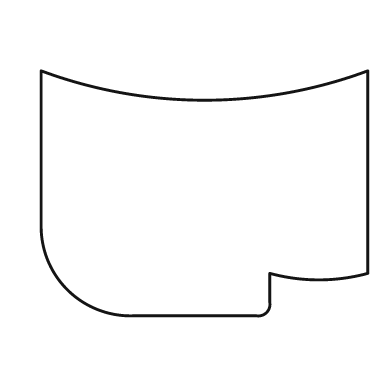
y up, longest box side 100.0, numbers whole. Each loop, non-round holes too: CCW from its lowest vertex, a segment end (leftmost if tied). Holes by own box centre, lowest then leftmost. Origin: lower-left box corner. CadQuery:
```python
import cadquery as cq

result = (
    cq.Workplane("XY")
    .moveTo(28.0, 0.0)
    .lineTo(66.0, 0.0)
    .threePointArc((69.0, 1.0), (70.0, 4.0))
    .lineTo(70.0, 13.0)
    .threePointArc((85.0, 11.0), (100.0, 13.0))
    .lineTo(100.0, 75.0)
    .threePointArc((50.0, 66.0), (0.0, 75.0))
    .lineTo(0.0, 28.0)
    .threePointArc((8.0, 8.0), (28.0, 0.0))
    .close()
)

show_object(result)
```